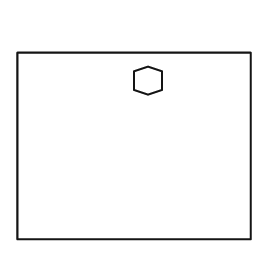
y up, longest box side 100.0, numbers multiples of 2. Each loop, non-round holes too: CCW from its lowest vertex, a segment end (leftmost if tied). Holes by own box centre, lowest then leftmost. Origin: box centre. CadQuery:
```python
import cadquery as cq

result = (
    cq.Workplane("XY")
    .moveTo(-50.0, -40.0)
    .lineTo(50.0, -40.0)
    .lineTo(50.0, 40.0)
    .lineTo(-50.0, 40.0)
    .close()
    .moveTo(6.0, 22.0)
    .lineTo(12.0, 24.0)
    .lineTo(12.0, 32.0)
    .lineTo(6.0, 34.0)
    .lineTo(0.0, 32.0)
    .lineTo(0.0, 24.0)
    .close()
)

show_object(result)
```